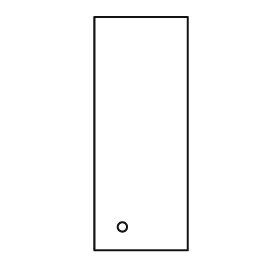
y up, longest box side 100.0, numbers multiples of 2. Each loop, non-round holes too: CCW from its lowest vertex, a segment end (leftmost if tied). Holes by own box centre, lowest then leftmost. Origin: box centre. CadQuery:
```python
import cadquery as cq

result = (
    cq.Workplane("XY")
    .moveTo(-20.0, -50.0)
    .lineTo(20.0, -50.0)
    .lineTo(20.0, 50.0)
    .lineTo(-20.0, 50.0)
    .close()
    .moveTo(-8.0, -40.0)
    .circle(2.0)
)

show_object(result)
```